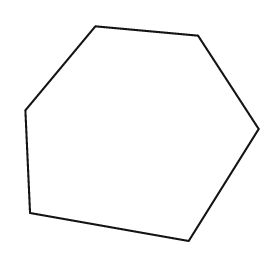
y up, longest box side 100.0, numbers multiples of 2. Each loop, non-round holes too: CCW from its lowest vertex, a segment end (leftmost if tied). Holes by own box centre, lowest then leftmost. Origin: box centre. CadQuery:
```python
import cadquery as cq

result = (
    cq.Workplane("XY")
    .moveTo(20.0, -46.0)
    .lineTo(50.0, 2.0)
    .lineTo(24.0, 42.0)
    .lineTo(-20.0, 46.0)
    .lineTo(-50.0, 10.0)
    .lineTo(-48.0, -34.0)
    .close()
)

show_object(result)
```